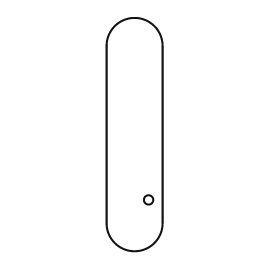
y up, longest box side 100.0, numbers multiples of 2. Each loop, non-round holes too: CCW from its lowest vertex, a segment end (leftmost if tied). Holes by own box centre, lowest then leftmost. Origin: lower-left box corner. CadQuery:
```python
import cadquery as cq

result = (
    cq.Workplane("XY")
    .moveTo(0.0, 12.0)
    .threePointArc((12.0, 0.0), (24.0, 12.0))
    .lineTo(24.0, 88.0)
    .threePointArc((12.0, 100.0), (0.0, 88.0))
    .close()
    .moveTo(18.0, 22.0)
    .circle(2.0)
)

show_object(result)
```